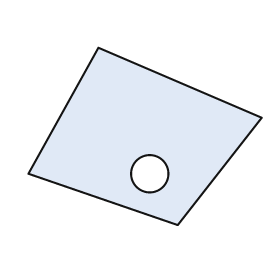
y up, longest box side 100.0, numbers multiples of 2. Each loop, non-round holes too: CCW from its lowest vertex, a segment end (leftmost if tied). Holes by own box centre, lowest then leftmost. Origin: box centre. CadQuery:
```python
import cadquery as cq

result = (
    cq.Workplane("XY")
    .moveTo(14.0, -38.0)
    .lineTo(50.0, 8.0)
    .lineTo(-20.0, 38.0)
    .lineTo(-50.0, -16.0)
    .close()
    .moveTo(2.0, -16.0)
    .circle(8.0)
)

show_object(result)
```